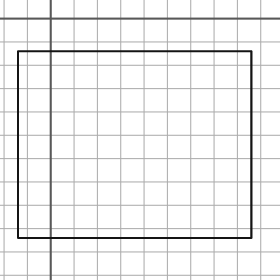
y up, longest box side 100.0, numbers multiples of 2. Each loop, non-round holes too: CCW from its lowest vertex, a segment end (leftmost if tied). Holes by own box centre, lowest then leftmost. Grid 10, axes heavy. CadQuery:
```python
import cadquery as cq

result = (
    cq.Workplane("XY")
    .moveTo(-14.0, -94.0)
    .lineTo(86.0, -94.0)
    .lineTo(86.0, -14.0)
    .lineTo(-14.0, -14.0)
    .close()
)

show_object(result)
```